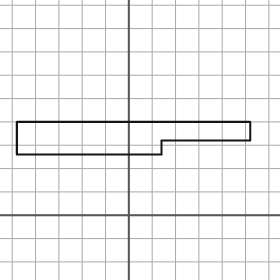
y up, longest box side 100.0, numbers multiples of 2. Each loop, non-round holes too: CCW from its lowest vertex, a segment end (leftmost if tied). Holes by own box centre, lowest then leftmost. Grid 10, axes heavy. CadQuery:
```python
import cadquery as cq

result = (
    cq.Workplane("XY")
    .moveTo(-48.0, 26.0)
    .lineTo(14.0, 26.0)
    .lineTo(14.0, 32.0)
    .lineTo(52.0, 32.0)
    .lineTo(52.0, 40.0)
    .lineTo(-48.0, 40.0)
    .close()
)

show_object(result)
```